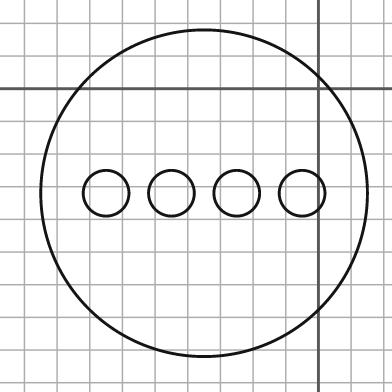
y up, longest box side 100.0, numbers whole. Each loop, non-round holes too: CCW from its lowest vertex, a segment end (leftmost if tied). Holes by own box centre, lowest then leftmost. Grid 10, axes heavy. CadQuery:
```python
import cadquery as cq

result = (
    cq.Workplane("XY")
    .moveTo(-35.0, -32.0)
    .circle(50.0)
    .moveTo(-65.0, -32.0)
    .circle(7.0)
    .moveTo(-45.0, -32.0)
    .circle(7.0)
    .moveTo(-25.0, -32.0)
    .circle(7.0)
    .moveTo(-5.0, -32.0)
    .circle(7.0)
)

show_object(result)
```